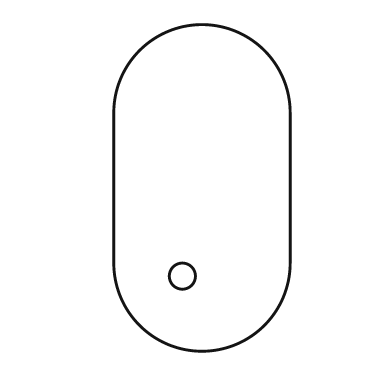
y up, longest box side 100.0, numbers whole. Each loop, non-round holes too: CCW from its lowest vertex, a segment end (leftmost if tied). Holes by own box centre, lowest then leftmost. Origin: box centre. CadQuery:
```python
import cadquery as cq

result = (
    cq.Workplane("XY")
    .moveTo(-27.0, -23.0)
    .threePointArc((0.0, -50.0), (27.0, -23.0))
    .lineTo(27.0, 23.0)
    .threePointArc((0.0, 50.0), (-27.0, 23.0))
    .close()
    .moveTo(-6.0, -27.0)
    .circle(4.0)
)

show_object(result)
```